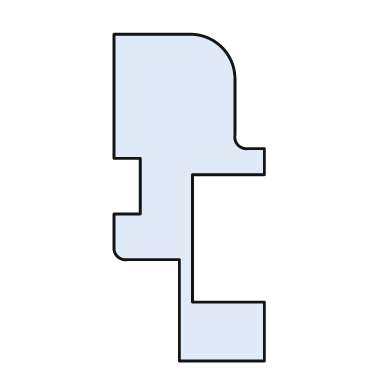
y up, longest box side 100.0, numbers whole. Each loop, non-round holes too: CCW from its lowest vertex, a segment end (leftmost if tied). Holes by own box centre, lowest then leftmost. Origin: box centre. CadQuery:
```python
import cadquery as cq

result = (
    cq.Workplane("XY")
    .moveTo(-3.0, -50.0)
    .lineTo(23.0, -50.0)
    .lineTo(23.0, -32.0)
    .lineTo(1.0, -32.0)
    .lineTo(1.0, 7.0)
    .lineTo(23.0, 7.0)
    .lineTo(23.0, 15.0)
    .lineTo(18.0, 15.0)
    .threePointArc((15.0, 16.0), (14.0, 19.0))
    .lineTo(14.0, 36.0)
    .threePointArc((10.0, 46.0), (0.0, 50.0))
    .lineTo(-23.0, 50.0)
    .lineTo(-23.0, 12.0)
    .lineTo(-15.0, 12.0)
    .lineTo(-15.0, -5.0)
    .lineTo(-23.0, -5.0)
    .lineTo(-23.0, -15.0)
    .threePointArc((-22.0, -18.0), (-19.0, -19.0))
    .lineTo(-3.0, -19.0)
    .close()
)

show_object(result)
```